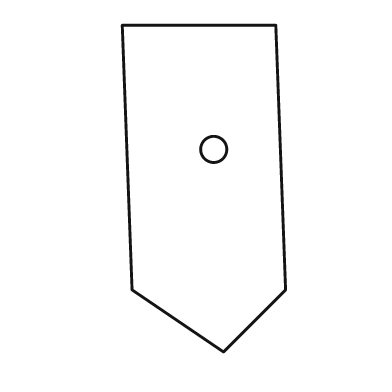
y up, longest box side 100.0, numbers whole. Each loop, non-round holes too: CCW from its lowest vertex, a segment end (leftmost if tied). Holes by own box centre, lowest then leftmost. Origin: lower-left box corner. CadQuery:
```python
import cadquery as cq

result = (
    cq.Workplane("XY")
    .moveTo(31.0, 0.0)
    .lineTo(50.0, 19.0)
    .lineTo(47.0, 100.0)
    .lineTo(0.0, 100.0)
    .lineTo(3.0, 19.0)
    .close()
    .moveTo(28.0, 62.0)
    .circle(4.0)
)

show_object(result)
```